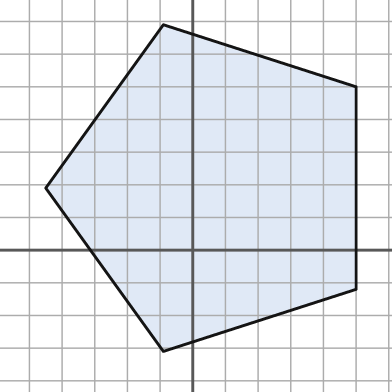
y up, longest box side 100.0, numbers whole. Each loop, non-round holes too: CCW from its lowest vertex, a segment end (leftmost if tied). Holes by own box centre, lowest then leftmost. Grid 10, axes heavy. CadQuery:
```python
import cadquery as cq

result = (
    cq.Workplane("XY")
    .moveTo(-9.0, -31.0)
    .lineTo(50.0, -12.0)
    .lineTo(50.0, 50.0)
    .lineTo(-9.0, 69.0)
    .lineTo(-45.0, 19.0)
    .close()
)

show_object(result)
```